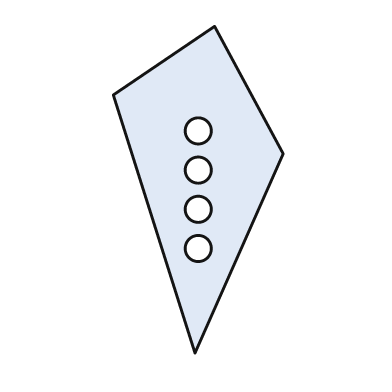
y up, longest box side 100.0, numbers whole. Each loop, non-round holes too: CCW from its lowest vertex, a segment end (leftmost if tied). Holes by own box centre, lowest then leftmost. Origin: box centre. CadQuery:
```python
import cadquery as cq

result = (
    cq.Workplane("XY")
    .moveTo(-1.0, -50.0)
    .lineTo(26.0, 11.0)
    .lineTo(5.0, 50.0)
    .lineTo(-26.0, 29.0)
    .close()
    .moveTo(0.0, -18.0)
    .circle(4.0)
    .moveTo(0.0, -6.0)
    .circle(4.0)
    .moveTo(0.0, 6.0)
    .circle(4.0)
    .moveTo(0.0, 18.0)
    .circle(4.0)
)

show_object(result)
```